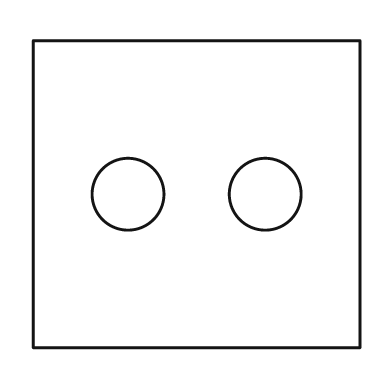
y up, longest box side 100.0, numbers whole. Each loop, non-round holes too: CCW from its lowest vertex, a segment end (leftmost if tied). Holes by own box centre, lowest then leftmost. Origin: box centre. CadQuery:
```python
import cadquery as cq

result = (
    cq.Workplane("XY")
    .moveTo(-50.0, -47.0)
    .lineTo(50.0, -47.0)
    .lineTo(50.0, 47.0)
    .lineTo(-50.0, 47.0)
    .close()
    .moveTo(-21.0, 0.0)
    .circle(11.0)
    .moveTo(21.0, 0.0)
    .circle(11.0)
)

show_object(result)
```